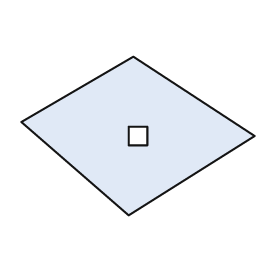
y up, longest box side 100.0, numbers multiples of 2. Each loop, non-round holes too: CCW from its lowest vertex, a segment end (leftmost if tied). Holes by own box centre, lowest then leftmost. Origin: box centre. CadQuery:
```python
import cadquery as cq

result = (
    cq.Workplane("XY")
    .moveTo(-4.0, -34.0)
    .lineTo(50.0, 0.0)
    .lineTo(-2.0, 34.0)
    .lineTo(-50.0, 6.0)
    .close()
    .moveTo(-4.0, -4.0)
    .lineTo(4.0, -4.0)
    .lineTo(4.0, 4.0)
    .lineTo(-4.0, 4.0)
    .close()
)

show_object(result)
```